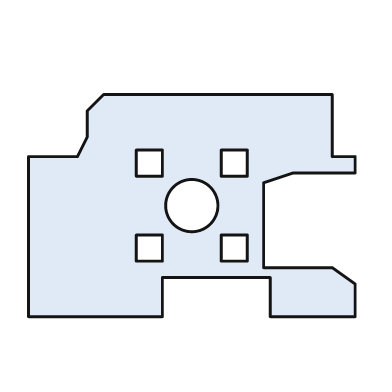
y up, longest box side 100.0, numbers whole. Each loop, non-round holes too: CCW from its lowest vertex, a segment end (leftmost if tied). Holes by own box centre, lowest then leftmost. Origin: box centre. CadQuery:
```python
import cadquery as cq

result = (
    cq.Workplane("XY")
    .moveTo(-50.0, -34.0)
    .lineTo(-9.0, -34.0)
    .lineTo(-9.0, -22.0)
    .lineTo(24.0, -22.0)
    .lineTo(24.0, -34.0)
    .lineTo(50.0, -34.0)
    .lineTo(50.0, -24.0)
    .lineTo(43.0, -19.0)
    .lineTo(22.0, -19.0)
    .lineTo(22.0, 7.0)
    .lineTo(31.0, 10.0)
    .lineTo(50.0, 10.0)
    .lineTo(50.0, 15.0)
    .lineTo(43.0, 15.0)
    .lineTo(43.0, 34.0)
    .lineTo(-27.0, 34.0)
    .lineTo(-32.0, 29.0)
    .lineTo(-32.0, 21.0)
    .lineTo(-35.0, 15.0)
    .lineTo(-50.0, 15.0)
    .close()
    .moveTo(-17.0, -17.0)
    .lineTo(-9.0, -17.0)
    .lineTo(-9.0, -9.0)
    .lineTo(-17.0, -9.0)
    .close()
    .moveTo(9.0, -17.0)
    .lineTo(17.0, -17.0)
    .lineTo(17.0, -9.0)
    .lineTo(9.0, -9.0)
    .close()
    .moveTo(0.0, 0.0)
    .circle(8.0)
    .moveTo(-17.0, 9.0)
    .lineTo(-9.0, 9.0)
    .lineTo(-9.0, 17.0)
    .lineTo(-17.0, 17.0)
    .close()
    .moveTo(9.0, 9.0)
    .lineTo(17.0, 9.0)
    .lineTo(17.0, 17.0)
    .lineTo(9.0, 17.0)
    .close()
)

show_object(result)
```